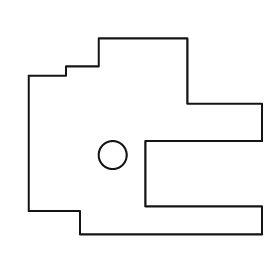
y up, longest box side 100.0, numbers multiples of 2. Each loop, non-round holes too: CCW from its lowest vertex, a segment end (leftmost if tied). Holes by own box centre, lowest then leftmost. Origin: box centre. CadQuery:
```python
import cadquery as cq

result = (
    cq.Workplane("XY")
    .moveTo(-28.0, -42.0)
    .lineTo(50.0, -42.0)
    .lineTo(50.0, -30.0)
    .lineTo(0.0, -30.0)
    .lineTo(0.0, -2.0)
    .lineTo(50.0, -2.0)
    .lineTo(50.0, 14.0)
    .lineTo(18.0, 14.0)
    .lineTo(18.0, 42.0)
    .lineTo(-20.0, 42.0)
    .lineTo(-20.0, 30.0)
    .lineTo(-34.0, 30.0)
    .lineTo(-34.0, 26.0)
    .lineTo(-50.0, 26.0)
    .lineTo(-50.0, -32.0)
    .lineTo(-28.0, -32.0)
    .close()
    .moveTo(-14.0, -8.0)
    .circle(6.0)
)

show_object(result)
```